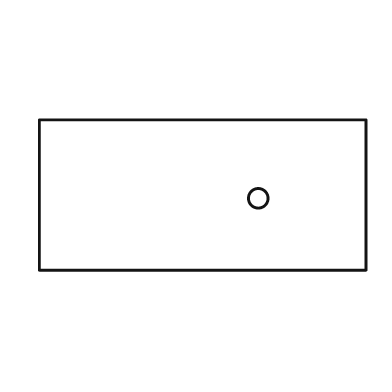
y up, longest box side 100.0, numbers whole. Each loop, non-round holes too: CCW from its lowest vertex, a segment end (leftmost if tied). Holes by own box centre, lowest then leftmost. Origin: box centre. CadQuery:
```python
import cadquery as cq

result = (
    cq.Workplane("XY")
    .moveTo(-50.0, -23.0)
    .lineTo(50.0, -23.0)
    .lineTo(50.0, 23.0)
    .lineTo(-50.0, 23.0)
    .close()
    .moveTo(17.0, -1.0)
    .circle(3.0)
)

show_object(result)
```